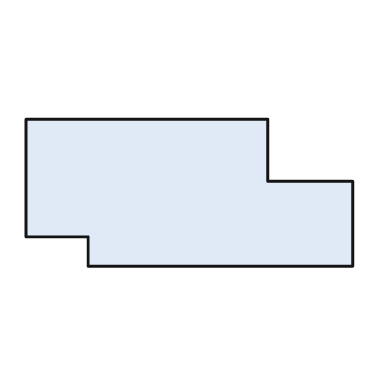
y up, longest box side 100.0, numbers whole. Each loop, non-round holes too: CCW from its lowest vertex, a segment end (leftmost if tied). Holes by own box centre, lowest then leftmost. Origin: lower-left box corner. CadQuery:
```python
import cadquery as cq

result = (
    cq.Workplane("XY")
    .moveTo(19.0, 0.0)
    .lineTo(100.0, 0.0)
    .lineTo(100.0, 26.0)
    .lineTo(74.0, 26.0)
    .lineTo(74.0, 45.0)
    .lineTo(0.0, 45.0)
    .lineTo(0.0, 9.0)
    .lineTo(19.0, 9.0)
    .close()
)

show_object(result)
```